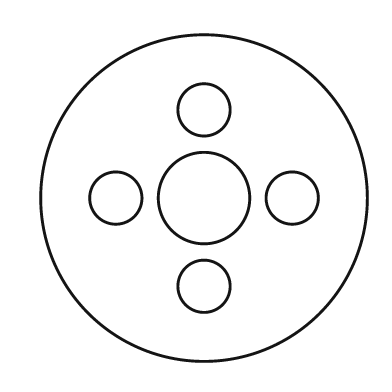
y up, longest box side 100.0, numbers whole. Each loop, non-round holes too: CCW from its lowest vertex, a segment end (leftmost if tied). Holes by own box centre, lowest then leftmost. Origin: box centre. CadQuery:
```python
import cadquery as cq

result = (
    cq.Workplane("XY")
    .moveTo(0.0, 0.0)
    .circle(50.0)
    .moveTo(0.0, -27.0)
    .circle(8.0)
    .moveTo(-27.0, 0.0)
    .circle(8.0)
    .moveTo(0.0, 0.0)
    .circle(14.0)
    .moveTo(27.0, 0.0)
    .circle(8.0)
    .moveTo(0.0, 27.0)
    .circle(8.0)
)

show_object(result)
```